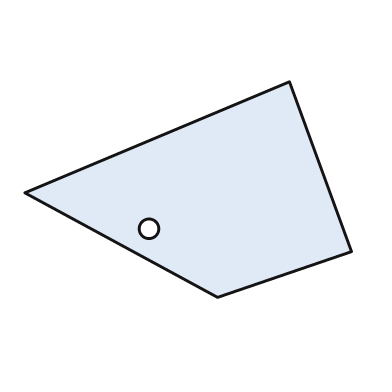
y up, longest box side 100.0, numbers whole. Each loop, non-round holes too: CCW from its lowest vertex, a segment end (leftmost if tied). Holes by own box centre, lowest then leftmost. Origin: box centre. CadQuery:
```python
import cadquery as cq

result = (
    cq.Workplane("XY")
    .moveTo(9.0, -33.0)
    .lineTo(50.0, -19.0)
    .lineTo(31.0, 33.0)
    .lineTo(-50.0, -1.0)
    .close()
    .moveTo(-12.0, -12.0)
    .circle(3.0)
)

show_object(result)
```